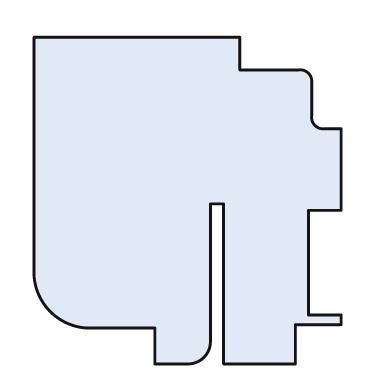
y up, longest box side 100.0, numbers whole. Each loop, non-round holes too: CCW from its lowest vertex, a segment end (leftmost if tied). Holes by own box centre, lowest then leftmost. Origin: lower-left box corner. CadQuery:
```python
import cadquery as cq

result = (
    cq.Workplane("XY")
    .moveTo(37.0, 0.0)
    .lineTo(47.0, 0.0)
    .threePointArc((52.0, 2.0), (54.0, 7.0))
    .lineTo(54.0, 49.0)
    .lineTo(58.0, 49.0)
    .lineTo(58.0, 0.0)
    .lineTo(80.0, 0.0)
    .lineTo(80.0, 12.0)
    .lineTo(94.0, 12.0)
    .lineTo(94.0, 15.0)
    .lineTo(84.0, 15.0)
    .lineTo(84.0, 47.0)
    .lineTo(94.0, 47.0)
    .lineTo(94.0, 72.0)
    .lineTo(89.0, 72.0)
    .threePointArc((86.0, 73.0), (85.0, 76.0))
    .lineTo(85.0, 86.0)
    .threePointArc((84.0, 89.0), (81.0, 90.0))
    .lineTo(63.0, 90.0)
    .lineTo(63.0, 100.0)
    .lineTo(0.0, 100.0)
    .lineTo(0.0, 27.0)
    .threePointArc((5.0, 16.0), (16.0, 11.0))
    .lineTo(37.0, 11.0)
    .close()
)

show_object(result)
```